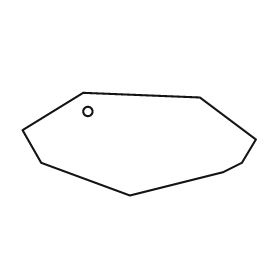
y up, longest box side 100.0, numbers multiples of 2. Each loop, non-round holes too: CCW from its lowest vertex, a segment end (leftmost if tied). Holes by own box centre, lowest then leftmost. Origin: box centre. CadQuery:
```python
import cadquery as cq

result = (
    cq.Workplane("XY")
    .moveTo(-4.0, -22.0)
    .lineTo(36.0, -12.0)
    .lineTo(44.0, -8.0)
    .lineTo(50.0, 2.0)
    .lineTo(26.0, 20.0)
    .lineTo(-24.0, 22.0)
    .lineTo(-50.0, 6.0)
    .lineTo(-42.0, -8.0)
    .close()
    .moveTo(-22.0, 14.0)
    .circle(2.0)
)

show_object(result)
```